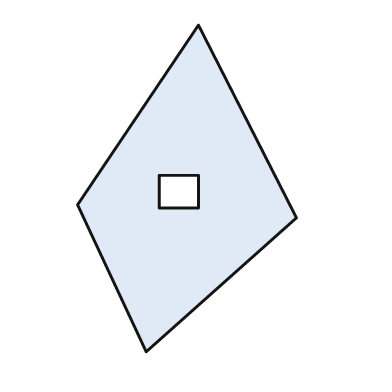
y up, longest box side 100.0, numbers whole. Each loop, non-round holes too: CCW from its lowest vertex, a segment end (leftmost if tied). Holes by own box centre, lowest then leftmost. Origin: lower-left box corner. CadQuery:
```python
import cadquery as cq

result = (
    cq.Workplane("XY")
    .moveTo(21.0, 0.0)
    .lineTo(67.0, 41.0)
    .lineTo(37.0, 100.0)
    .lineTo(0.0, 45.0)
    .close()
    .moveTo(25.0, 44.0)
    .lineTo(37.0, 44.0)
    .lineTo(37.0, 54.0)
    .lineTo(25.0, 54.0)
    .close()
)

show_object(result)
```